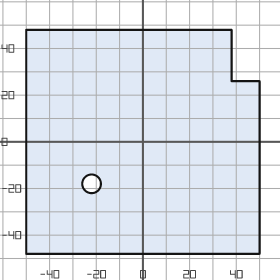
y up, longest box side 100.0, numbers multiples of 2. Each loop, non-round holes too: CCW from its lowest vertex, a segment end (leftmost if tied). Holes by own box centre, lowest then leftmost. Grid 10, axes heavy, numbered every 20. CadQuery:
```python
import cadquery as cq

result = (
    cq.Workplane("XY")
    .moveTo(-50.0, -48.0)
    .lineTo(50.0, -48.0)
    .lineTo(50.0, 26.0)
    .lineTo(38.0, 26.0)
    .lineTo(38.0, 48.0)
    .lineTo(-50.0, 48.0)
    .close()
    .moveTo(-22.0, -18.0)
    .circle(4.0)
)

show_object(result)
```